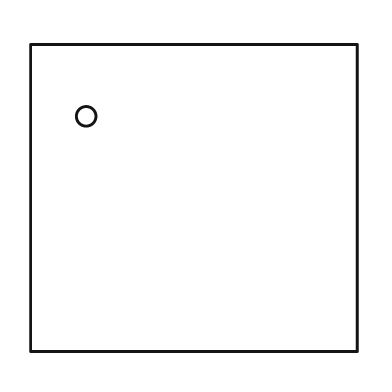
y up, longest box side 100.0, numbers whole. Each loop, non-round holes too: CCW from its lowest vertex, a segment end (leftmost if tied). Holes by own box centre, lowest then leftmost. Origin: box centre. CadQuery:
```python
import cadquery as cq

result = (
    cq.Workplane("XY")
    .moveTo(-50.0, -47.0)
    .lineTo(50.0, -47.0)
    .lineTo(50.0, 47.0)
    .lineTo(-50.0, 47.0)
    .close()
    .moveTo(-33.0, 25.0)
    .circle(3.0)
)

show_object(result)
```